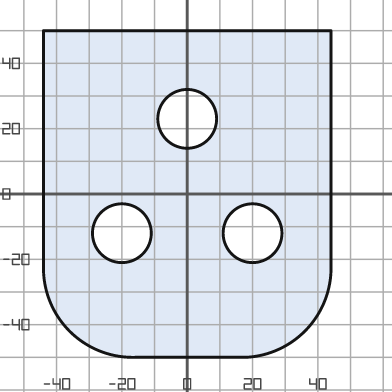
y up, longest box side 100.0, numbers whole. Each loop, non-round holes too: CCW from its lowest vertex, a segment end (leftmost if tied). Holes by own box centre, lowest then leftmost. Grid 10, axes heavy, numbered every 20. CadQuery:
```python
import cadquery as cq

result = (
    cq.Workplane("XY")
    .moveTo(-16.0, -50.0)
    .lineTo(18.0, -50.0)
    .threePointArc((36.0, -42.0), (44.0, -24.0))
    .lineTo(44.0, 50.0)
    .lineTo(-44.0, 50.0)
    .lineTo(-44.0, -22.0)
    .threePointArc((-36.0, -42.0), (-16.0, -50.0))
    .close()
    .moveTo(-20.0, -12.0)
    .circle(9.0)
    .moveTo(20.0, -12.0)
    .circle(9.0)
    .moveTo(0.0, 23.0)
    .circle(9.0)
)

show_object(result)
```